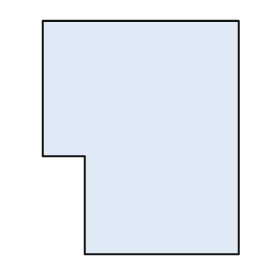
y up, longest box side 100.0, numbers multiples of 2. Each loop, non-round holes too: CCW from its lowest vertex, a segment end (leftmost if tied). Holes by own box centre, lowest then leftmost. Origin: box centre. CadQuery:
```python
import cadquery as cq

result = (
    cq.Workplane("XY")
    .moveTo(-24.0, -50.0)
    .lineTo(42.0, -50.0)
    .lineTo(42.0, 50.0)
    .lineTo(-42.0, 50.0)
    .lineTo(-42.0, -8.0)
    .lineTo(-24.0, -8.0)
    .close()
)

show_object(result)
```